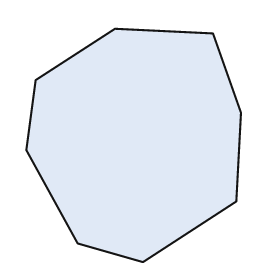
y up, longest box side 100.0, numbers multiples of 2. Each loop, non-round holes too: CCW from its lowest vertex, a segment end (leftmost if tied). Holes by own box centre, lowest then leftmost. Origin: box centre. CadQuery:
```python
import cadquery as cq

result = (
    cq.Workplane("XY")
    .moveTo(4.0, -50.0)
    .lineTo(44.0, -24.0)
    .lineTo(46.0, 14.0)
    .lineTo(34.0, 48.0)
    .lineTo(-8.0, 50.0)
    .lineTo(-42.0, 28.0)
    .lineTo(-46.0, -2.0)
    .lineTo(-24.0, -42.0)
    .close()
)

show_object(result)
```